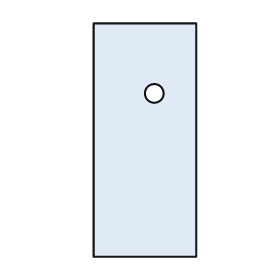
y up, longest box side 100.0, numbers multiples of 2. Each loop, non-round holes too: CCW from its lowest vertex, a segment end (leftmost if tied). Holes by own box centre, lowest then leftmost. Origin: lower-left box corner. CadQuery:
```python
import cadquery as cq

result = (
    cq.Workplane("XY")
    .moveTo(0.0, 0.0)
    .lineTo(44.0, 0.0)
    .lineTo(44.0, 100.0)
    .lineTo(0.0, 100.0)
    .close()
    .moveTo(26.0, 70.0)
    .circle(4.0)
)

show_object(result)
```